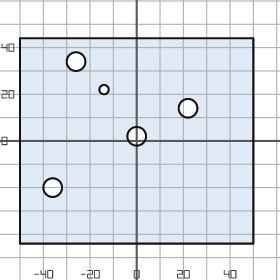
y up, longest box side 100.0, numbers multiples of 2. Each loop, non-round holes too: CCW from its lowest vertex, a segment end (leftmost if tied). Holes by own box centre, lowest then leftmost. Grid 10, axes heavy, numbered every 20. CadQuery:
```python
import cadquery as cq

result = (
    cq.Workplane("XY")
    .moveTo(-50.0, -44.0)
    .lineTo(50.0, -44.0)
    .lineTo(50.0, 44.0)
    .lineTo(-50.0, 44.0)
    .close()
    .moveTo(-36.0, -20.0)
    .circle(4.0)
    .moveTo(0.0, 2.0)
    .circle(4.0)
    .moveTo(22.0, 14.0)
    .circle(4.0)
    .moveTo(-14.0, 22.0)
    .circle(2.0)
    .moveTo(-26.0, 34.0)
    .circle(4.0)
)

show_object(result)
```